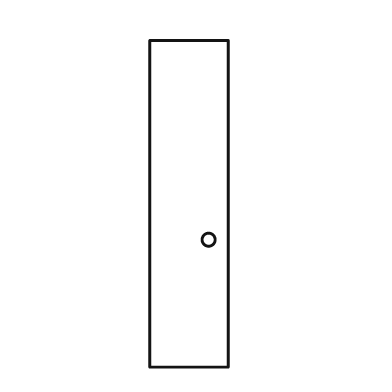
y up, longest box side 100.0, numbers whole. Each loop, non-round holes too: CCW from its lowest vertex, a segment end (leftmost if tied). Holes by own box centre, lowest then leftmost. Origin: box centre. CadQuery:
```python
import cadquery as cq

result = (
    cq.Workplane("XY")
    .moveTo(-12.0, -50.0)
    .lineTo(12.0, -50.0)
    .lineTo(12.0, 50.0)
    .lineTo(-12.0, 50.0)
    .close()
    .moveTo(6.0, -11.0)
    .circle(2.0)
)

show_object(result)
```